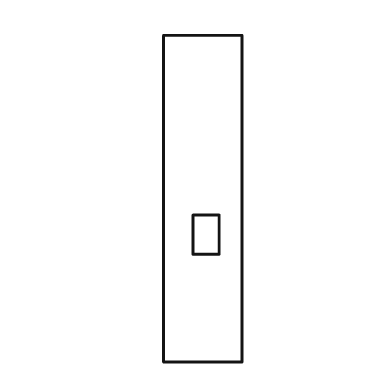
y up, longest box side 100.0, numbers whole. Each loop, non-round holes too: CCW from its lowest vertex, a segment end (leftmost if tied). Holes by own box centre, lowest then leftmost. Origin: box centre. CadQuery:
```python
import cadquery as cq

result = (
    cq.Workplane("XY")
    .moveTo(-12.0, -50.0)
    .lineTo(12.0, -50.0)
    .lineTo(12.0, 50.0)
    .lineTo(-12.0, 50.0)
    .close()
    .moveTo(-3.0, -17.0)
    .lineTo(5.0, -17.0)
    .lineTo(5.0, -5.0)
    .lineTo(-3.0, -5.0)
    .close()
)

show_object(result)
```